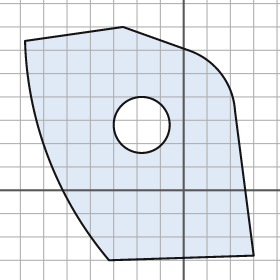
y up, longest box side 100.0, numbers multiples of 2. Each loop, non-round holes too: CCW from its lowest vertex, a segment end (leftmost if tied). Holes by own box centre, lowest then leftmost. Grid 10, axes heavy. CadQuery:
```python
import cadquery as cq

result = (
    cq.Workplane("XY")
    .moveTo(-32.0, -30.0)
    .lineTo(30.0, -28.0)
    .lineTo(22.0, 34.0)
    .threePointArc((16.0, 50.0), (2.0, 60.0))
    .lineTo(-26.0, 70.0)
    .lineTo(-68.0, 64.0)
    .threePointArc((-58.0, 14.0), (-32.0, -30.0))
    .close()
    .moveTo(-18.0, 28.0)
    .circle(12.0)
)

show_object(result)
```